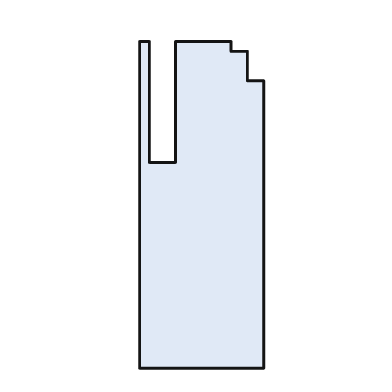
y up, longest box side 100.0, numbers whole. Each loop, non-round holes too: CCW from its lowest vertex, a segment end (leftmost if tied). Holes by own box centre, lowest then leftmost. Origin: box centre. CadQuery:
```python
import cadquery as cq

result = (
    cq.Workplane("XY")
    .moveTo(-19.0, -50.0)
    .lineTo(19.0, -50.0)
    .lineTo(19.0, 38.0)
    .lineTo(14.0, 38.0)
    .lineTo(14.0, 47.0)
    .lineTo(9.0, 47.0)
    .lineTo(9.0, 50.0)
    .lineTo(-8.0, 50.0)
    .lineTo(-8.0, 13.0)
    .lineTo(-16.0, 13.0)
    .lineTo(-16.0, 50.0)
    .lineTo(-19.0, 50.0)
    .close()
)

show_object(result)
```